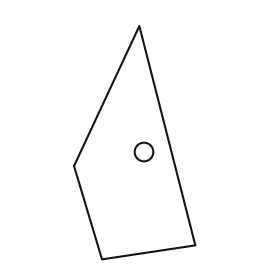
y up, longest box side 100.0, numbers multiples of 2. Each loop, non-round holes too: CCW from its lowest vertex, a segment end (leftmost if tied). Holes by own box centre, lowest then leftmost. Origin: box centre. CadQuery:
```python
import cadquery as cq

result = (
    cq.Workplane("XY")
    .moveTo(-14.0, -50.0)
    .lineTo(26.0, -44.0)
    .lineTo(2.0, 50.0)
    .lineTo(-26.0, -10.0)
    .close()
    .moveTo(4.0, -4.0)
    .circle(4.0)
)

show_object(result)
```